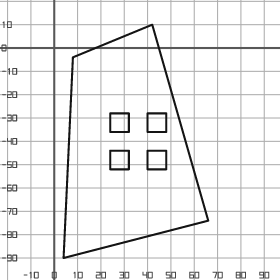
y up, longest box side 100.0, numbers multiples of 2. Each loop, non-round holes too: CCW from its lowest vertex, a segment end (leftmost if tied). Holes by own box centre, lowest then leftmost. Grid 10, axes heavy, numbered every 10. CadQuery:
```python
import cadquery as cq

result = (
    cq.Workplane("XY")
    .moveTo(4.0, -90.0)
    .lineTo(66.0, -74.0)
    .lineTo(42.0, 10.0)
    .lineTo(8.0, -4.0)
    .close()
    .moveTo(24.0, -52.0)
    .lineTo(32.0, -52.0)
    .lineTo(32.0, -44.0)
    .lineTo(24.0, -44.0)
    .close()
    .moveTo(40.0, -52.0)
    .lineTo(48.0, -52.0)
    .lineTo(48.0, -44.0)
    .lineTo(40.0, -44.0)
    .close()
    .moveTo(24.0, -36.0)
    .lineTo(32.0, -36.0)
    .lineTo(32.0, -28.0)
    .lineTo(24.0, -28.0)
    .close()
    .moveTo(40.0, -36.0)
    .lineTo(48.0, -36.0)
    .lineTo(48.0, -28.0)
    .lineTo(40.0, -28.0)
    .close()
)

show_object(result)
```